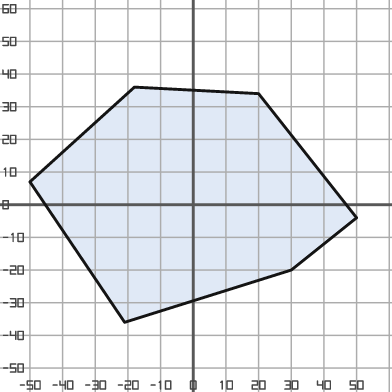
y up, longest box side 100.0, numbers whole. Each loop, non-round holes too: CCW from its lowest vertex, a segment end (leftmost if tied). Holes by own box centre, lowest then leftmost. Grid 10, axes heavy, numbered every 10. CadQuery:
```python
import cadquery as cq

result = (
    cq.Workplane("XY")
    .moveTo(-21.0, -36.0)
    .lineTo(30.0, -20.0)
    .lineTo(50.0, -4.0)
    .lineTo(20.0, 34.0)
    .lineTo(-18.0, 36.0)
    .lineTo(-50.0, 7.0)
    .close()
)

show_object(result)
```